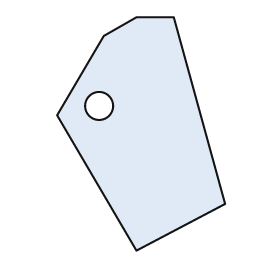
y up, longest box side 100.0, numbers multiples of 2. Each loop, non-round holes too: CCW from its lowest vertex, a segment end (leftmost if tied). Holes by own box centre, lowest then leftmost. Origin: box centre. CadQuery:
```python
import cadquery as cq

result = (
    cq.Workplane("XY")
    .moveTo(-2.0, -50.0)
    .lineTo(36.0, -30.0)
    .lineTo(14.0, 50.0)
    .lineTo(-2.0, 50.0)
    .lineTo(-16.0, 42.0)
    .lineTo(-36.0, 8.0)
    .close()
    .moveTo(-18.0, 12.0)
    .circle(6.0)
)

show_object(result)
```